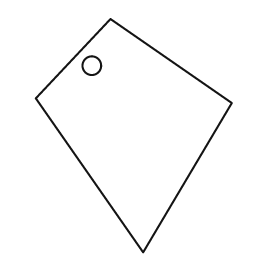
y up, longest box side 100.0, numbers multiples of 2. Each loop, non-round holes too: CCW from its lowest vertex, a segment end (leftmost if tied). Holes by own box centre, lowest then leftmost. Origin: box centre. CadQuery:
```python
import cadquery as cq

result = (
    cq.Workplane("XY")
    .moveTo(4.0, -50.0)
    .lineTo(42.0, 14.0)
    .lineTo(-10.0, 50.0)
    .lineTo(-42.0, 16.0)
    .close()
    .moveTo(-18.0, 30.0)
    .circle(4.0)
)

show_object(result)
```